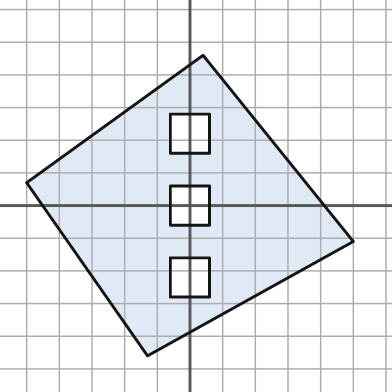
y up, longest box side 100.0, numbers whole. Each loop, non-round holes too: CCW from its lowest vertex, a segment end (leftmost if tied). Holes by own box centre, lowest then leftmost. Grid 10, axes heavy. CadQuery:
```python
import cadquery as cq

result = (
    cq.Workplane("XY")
    .moveTo(-13.0, -46.0)
    .lineTo(50.0, -11.0)
    .lineTo(4.0, 46.0)
    .lineTo(-50.0, 7.0)
    .close()
    .moveTo(-6.0, -28.0)
    .lineTo(6.0, -28.0)
    .lineTo(6.0, -16.0)
    .lineTo(-6.0, -16.0)
    .close()
    .moveTo(-6.0, -6.0)
    .lineTo(6.0, -6.0)
    .lineTo(6.0, 6.0)
    .lineTo(-6.0, 6.0)
    .close()
    .moveTo(-6.0, 16.0)
    .lineTo(6.0, 16.0)
    .lineTo(6.0, 28.0)
    .lineTo(-6.0, 28.0)
    .close()
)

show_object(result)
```